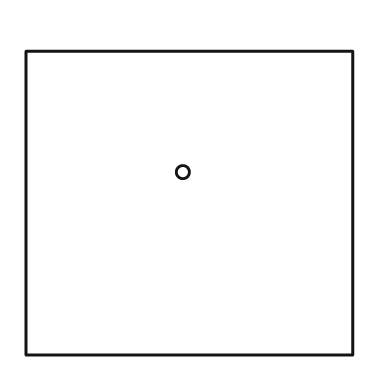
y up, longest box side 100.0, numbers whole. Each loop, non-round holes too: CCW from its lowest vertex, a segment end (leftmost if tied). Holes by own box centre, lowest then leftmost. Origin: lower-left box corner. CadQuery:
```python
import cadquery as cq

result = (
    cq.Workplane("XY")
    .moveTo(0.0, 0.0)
    .lineTo(100.0, 0.0)
    .lineTo(100.0, 93.0)
    .lineTo(0.0, 93.0)
    .close()
    .moveTo(48.0, 56.0)
    .circle(2.0)
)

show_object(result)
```